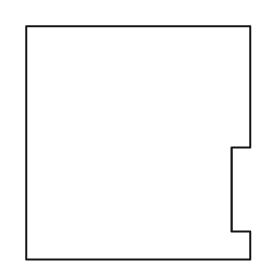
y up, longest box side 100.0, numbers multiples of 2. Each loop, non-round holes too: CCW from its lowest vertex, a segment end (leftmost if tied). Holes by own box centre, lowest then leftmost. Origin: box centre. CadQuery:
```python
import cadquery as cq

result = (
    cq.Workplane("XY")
    .moveTo(-48.0, -50.0)
    .lineTo(48.0, -50.0)
    .lineTo(48.0, -38.0)
    .lineTo(40.0, -38.0)
    .lineTo(40.0, -2.0)
    .lineTo(48.0, -2.0)
    .lineTo(48.0, 50.0)
    .lineTo(-48.0, 50.0)
    .close()
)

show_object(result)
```